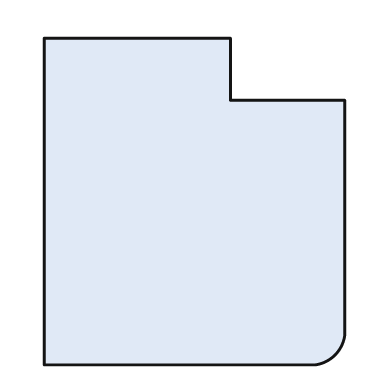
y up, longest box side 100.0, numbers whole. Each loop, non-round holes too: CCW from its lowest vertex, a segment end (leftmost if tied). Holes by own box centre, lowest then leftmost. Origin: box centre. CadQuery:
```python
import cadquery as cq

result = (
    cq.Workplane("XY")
    .moveTo(-46.0, -50.0)
    .lineTo(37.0, -50.0)
    .threePointArc((43.0, -47.0), (46.0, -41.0))
    .lineTo(46.0, 31.0)
    .lineTo(11.0, 31.0)
    .lineTo(11.0, 50.0)
    .lineTo(-46.0, 50.0)
    .close()
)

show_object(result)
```